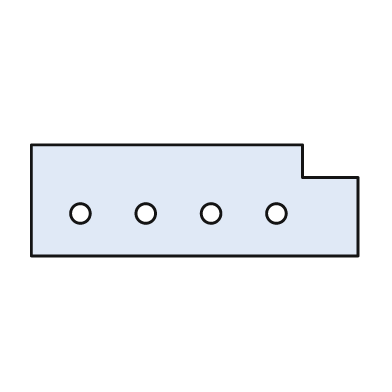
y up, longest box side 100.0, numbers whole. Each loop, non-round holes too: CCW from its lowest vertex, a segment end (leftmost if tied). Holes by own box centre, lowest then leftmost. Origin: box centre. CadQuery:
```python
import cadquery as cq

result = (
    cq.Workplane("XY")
    .moveTo(-50.0, -17.0)
    .lineTo(50.0, -17.0)
    .lineTo(50.0, 7.0)
    .lineTo(33.0, 7.0)
    .lineTo(33.0, 17.0)
    .lineTo(-50.0, 17.0)
    .close()
    .moveTo(-35.0, -4.0)
    .circle(3.0)
    .moveTo(-15.0, -4.0)
    .circle(3.0)
    .moveTo(5.0, -4.0)
    .circle(3.0)
    .moveTo(25.0, -4.0)
    .circle(3.0)
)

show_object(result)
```